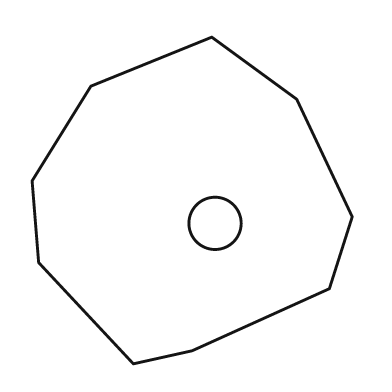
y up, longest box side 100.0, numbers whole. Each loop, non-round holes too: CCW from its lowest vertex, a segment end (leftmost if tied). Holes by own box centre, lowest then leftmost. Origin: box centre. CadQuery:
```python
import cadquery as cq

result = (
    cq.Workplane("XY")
    .moveTo(-18.0, -50.0)
    .lineTo(0.0, -46.0)
    .lineTo(42.0, -27.0)
    .lineTo(49.0, -5.0)
    .lineTo(32.0, 31.0)
    .lineTo(6.0, 50.0)
    .lineTo(-31.0, 35.0)
    .lineTo(-49.0, 6.0)
    .lineTo(-47.0, -19.0)
    .close()
    .moveTo(7.0, -7.0)
    .circle(8.0)
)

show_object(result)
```